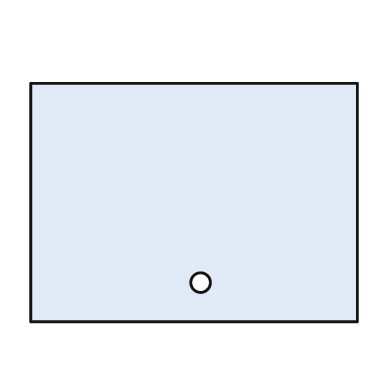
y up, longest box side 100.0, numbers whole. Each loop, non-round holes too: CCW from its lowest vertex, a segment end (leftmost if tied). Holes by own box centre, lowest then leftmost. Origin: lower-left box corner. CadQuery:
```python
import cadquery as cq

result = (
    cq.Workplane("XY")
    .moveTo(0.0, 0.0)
    .lineTo(100.0, 0.0)
    .lineTo(100.0, 73.0)
    .lineTo(0.0, 73.0)
    .close()
    .moveTo(52.0, 12.0)
    .circle(3.0)
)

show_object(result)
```